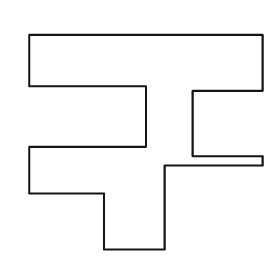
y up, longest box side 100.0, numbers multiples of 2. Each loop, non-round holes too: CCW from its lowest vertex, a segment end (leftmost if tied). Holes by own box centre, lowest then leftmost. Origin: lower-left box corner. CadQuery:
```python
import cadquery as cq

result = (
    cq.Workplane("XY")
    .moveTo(32.0, 0.0)
    .lineTo(58.0, 0.0)
    .lineTo(58.0, 36.0)
    .lineTo(100.0, 36.0)
    .lineTo(100.0, 40.0)
    .lineTo(70.0, 40.0)
    .lineTo(70.0, 68.0)
    .lineTo(100.0, 68.0)
    .lineTo(100.0, 92.0)
    .lineTo(0.0, 92.0)
    .lineTo(0.0, 70.0)
    .lineTo(50.0, 70.0)
    .lineTo(50.0, 44.0)
    .lineTo(0.0, 44.0)
    .lineTo(0.0, 24.0)
    .lineTo(32.0, 24.0)
    .close()
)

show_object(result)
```